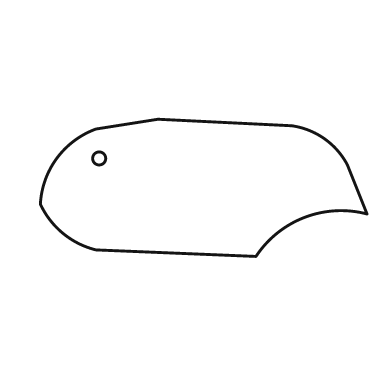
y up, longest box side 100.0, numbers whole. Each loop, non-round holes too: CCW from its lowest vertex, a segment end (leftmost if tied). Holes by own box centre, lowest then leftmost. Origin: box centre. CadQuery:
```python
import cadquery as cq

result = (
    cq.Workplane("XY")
    .moveTo(16.0, -21.0)
    .threePointArc((31.0, -9.0), (50.0, -8.0))
    .lineTo(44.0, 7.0)
    .threePointArc((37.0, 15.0), (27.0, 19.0))
    .lineTo(-14.0, 21.0)
    .lineTo(-33.0, 18.0)
    .threePointArc((-45.0, 9.0), (-50.0, -5.0))
    .threePointArc((-43.0, -14.0), (-33.0, -19.0))
    .close()
    .moveTo(-32.0, 9.0)
    .circle(2.0)
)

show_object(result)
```